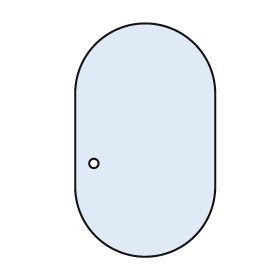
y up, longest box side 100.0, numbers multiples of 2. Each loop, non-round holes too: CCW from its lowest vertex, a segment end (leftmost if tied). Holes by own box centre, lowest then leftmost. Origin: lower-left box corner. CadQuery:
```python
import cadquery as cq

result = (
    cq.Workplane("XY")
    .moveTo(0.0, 30.0)
    .threePointArc((30.0, 0.0), (60.0, 30.0))
    .lineTo(60.0, 70.0)
    .threePointArc((30.0, 100.0), (0.0, 70.0))
    .close()
    .moveTo(8.0, 40.0)
    .circle(2.0)
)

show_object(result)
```